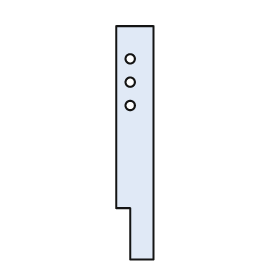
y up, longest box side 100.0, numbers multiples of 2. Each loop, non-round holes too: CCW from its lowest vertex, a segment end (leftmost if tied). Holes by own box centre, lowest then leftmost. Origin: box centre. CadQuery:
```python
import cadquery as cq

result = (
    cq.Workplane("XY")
    .moveTo(-2.0, -50.0)
    .lineTo(8.0, -50.0)
    .lineTo(8.0, 50.0)
    .lineTo(-8.0, 50.0)
    .lineTo(-8.0, -28.0)
    .lineTo(-2.0, -28.0)
    .close()
    .moveTo(-2.0, 16.0)
    .circle(2.0)
    .moveTo(-2.0, 26.0)
    .circle(2.0)
    .moveTo(-2.0, 36.0)
    .circle(2.0)
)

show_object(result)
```